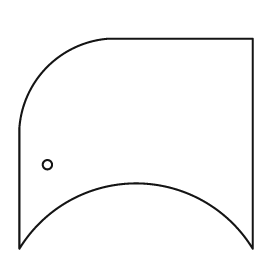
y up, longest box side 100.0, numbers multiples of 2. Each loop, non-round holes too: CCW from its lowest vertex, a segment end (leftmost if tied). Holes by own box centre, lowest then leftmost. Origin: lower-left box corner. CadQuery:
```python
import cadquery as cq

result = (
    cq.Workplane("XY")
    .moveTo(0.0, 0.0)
    .threePointArc((50.0, 28.0), (100.0, 0.0))
    .lineTo(100.0, 90.0)
    .lineTo(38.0, 90.0)
    .threePointArc((12.0, 78.0), (0.0, 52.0))
    .close()
    .moveTo(12.0, 36.0)
    .circle(2.0)
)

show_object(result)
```